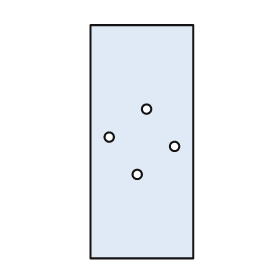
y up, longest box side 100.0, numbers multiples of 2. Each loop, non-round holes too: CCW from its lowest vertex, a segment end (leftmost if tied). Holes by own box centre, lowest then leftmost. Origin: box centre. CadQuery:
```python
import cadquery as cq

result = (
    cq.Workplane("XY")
    .moveTo(-22.0, -50.0)
    .lineTo(22.0, -50.0)
    .lineTo(22.0, 50.0)
    .lineTo(-22.0, 50.0)
    .close()
    .moveTo(-2.0, -14.0)
    .circle(2.0)
    .moveTo(14.0, -2.0)
    .circle(2.0)
    .moveTo(-14.0, 2.0)
    .circle(2.0)
    .moveTo(2.0, 14.0)
    .circle(2.0)
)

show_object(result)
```